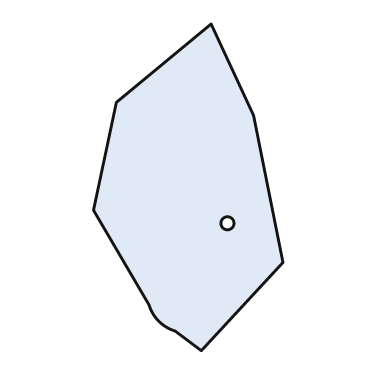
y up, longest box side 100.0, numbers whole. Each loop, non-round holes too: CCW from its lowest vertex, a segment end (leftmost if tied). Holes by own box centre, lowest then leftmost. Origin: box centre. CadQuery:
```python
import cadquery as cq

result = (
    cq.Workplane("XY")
    .moveTo(4.0, -50.0)
    .lineTo(29.0, -23.0)
    .lineTo(20.0, 22.0)
    .lineTo(7.0, 50.0)
    .lineTo(-22.0, 26.0)
    .lineTo(-29.0, -7.0)
    .lineTo(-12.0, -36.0)
    .threePointArc((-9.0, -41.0), (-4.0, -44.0))
    .close()
    .moveTo(12.0, -11.0)
    .circle(2.0)
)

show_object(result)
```